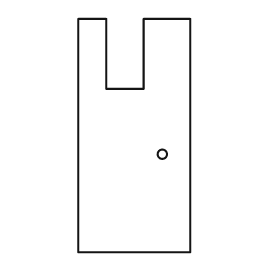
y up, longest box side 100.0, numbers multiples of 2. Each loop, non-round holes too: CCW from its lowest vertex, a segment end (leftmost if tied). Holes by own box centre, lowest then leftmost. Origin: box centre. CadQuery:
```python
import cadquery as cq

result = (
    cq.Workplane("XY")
    .moveTo(-24.0, -50.0)
    .lineTo(24.0, -50.0)
    .lineTo(24.0, 50.0)
    .lineTo(4.0, 50.0)
    .lineTo(4.0, 20.0)
    .lineTo(-12.0, 20.0)
    .lineTo(-12.0, 50.0)
    .lineTo(-24.0, 50.0)
    .close()
    .moveTo(12.0, -8.0)
    .circle(2.0)
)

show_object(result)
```